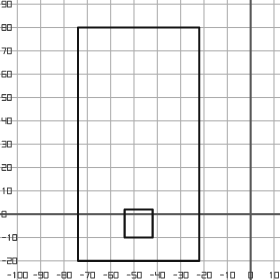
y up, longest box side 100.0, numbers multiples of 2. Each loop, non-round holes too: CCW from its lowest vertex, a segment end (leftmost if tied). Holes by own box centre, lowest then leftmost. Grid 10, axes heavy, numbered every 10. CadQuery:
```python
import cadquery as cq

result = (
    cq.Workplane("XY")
    .moveTo(-74.0, -20.0)
    .lineTo(-22.0, -20.0)
    .lineTo(-22.0, 80.0)
    .lineTo(-74.0, 80.0)
    .close()
    .moveTo(-54.0, -10.0)
    .lineTo(-42.0, -10.0)
    .lineTo(-42.0, 2.0)
    .lineTo(-54.0, 2.0)
    .close()
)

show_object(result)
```